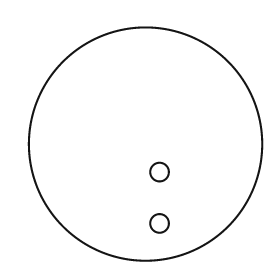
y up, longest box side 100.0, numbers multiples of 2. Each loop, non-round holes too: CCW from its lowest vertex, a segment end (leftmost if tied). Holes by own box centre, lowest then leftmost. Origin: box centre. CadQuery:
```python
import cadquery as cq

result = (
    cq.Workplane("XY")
    .moveTo(0.0, 0.0)
    .circle(50.0)
    .moveTo(6.0, -34.0)
    .circle(4.0)
    .moveTo(6.0, -12.0)
    .circle(4.0)
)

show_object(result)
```